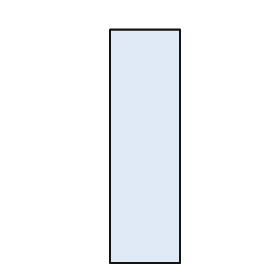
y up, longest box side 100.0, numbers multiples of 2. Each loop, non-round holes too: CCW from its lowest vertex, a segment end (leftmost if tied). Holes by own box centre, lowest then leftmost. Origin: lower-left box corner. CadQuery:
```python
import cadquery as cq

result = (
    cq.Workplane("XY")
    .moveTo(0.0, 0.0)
    .lineTo(30.0, 0.0)
    .lineTo(30.0, 100.0)
    .lineTo(0.0, 100.0)
    .close()
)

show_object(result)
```